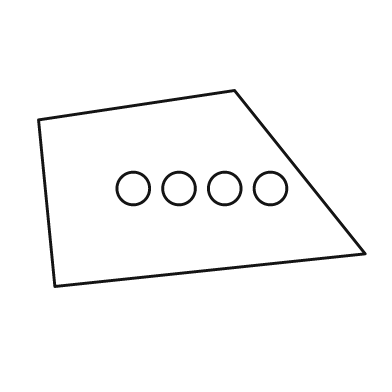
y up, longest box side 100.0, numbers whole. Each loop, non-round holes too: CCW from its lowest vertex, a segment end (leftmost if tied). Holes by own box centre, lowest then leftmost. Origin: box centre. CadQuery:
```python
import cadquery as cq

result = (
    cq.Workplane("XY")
    .moveTo(-45.0, -30.0)
    .lineTo(50.0, -20.0)
    .lineTo(10.0, 30.0)
    .lineTo(-50.0, 21.0)
    .close()
    .moveTo(-21.0, 0.0)
    .circle(5.0)
    .moveTo(-7.0, 0.0)
    .circle(5.0)
    .moveTo(7.0, 0.0)
    .circle(5.0)
    .moveTo(21.0, 0.0)
    .circle(5.0)
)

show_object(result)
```